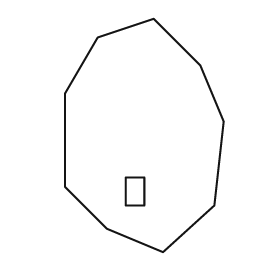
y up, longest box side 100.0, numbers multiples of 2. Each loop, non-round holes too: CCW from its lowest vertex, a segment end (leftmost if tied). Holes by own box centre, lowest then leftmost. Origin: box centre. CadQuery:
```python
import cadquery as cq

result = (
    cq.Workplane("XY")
    .moveTo(8.0, -50.0)
    .lineTo(30.0, -30.0)
    .lineTo(34.0, 6.0)
    .lineTo(24.0, 30.0)
    .lineTo(4.0, 50.0)
    .lineTo(-20.0, 42.0)
    .lineTo(-34.0, 18.0)
    .lineTo(-34.0, -22.0)
    .lineTo(-16.0, -40.0)
    .close()
    .moveTo(-8.0, -30.0)
    .lineTo(0.0, -30.0)
    .lineTo(0.0, -18.0)
    .lineTo(-8.0, -18.0)
    .close()
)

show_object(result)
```